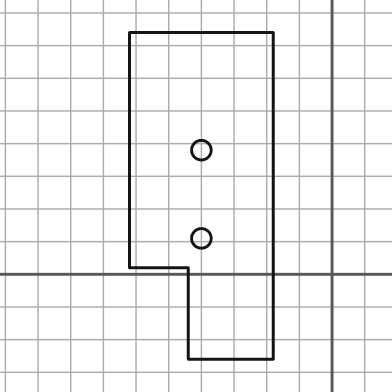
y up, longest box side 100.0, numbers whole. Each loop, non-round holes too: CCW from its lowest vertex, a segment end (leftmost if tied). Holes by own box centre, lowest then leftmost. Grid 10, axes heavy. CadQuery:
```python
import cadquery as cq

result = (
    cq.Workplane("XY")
    .moveTo(-44.0, -26.0)
    .lineTo(-18.0, -26.0)
    .lineTo(-18.0, 74.0)
    .lineTo(-62.0, 74.0)
    .lineTo(-62.0, 2.0)
    .lineTo(-44.0, 2.0)
    .close()
    .moveTo(-40.0, 11.0)
    .circle(3.0)
    .moveTo(-40.0, 38.0)
    .circle(3.0)
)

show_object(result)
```